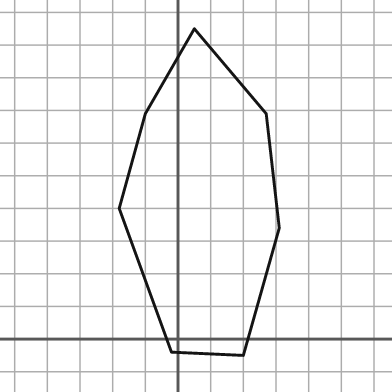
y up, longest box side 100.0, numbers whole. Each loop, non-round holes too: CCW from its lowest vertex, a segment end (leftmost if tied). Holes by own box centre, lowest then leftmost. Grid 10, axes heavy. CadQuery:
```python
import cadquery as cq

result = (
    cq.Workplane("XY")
    .moveTo(20.0, -5.0)
    .lineTo(31.0, 34.0)
    .lineTo(27.0, 69.0)
    .lineTo(5.0, 95.0)
    .lineTo(-10.0, 69.0)
    .lineTo(-18.0, 40.0)
    .lineTo(-2.0, -4.0)
    .close()
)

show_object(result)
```